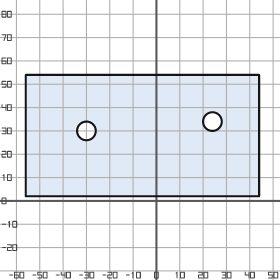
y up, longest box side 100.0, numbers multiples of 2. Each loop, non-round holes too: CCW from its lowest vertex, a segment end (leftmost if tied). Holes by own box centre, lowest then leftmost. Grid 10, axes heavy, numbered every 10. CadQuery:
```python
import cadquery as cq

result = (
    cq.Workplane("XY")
    .moveTo(-56.0, 2.0)
    .lineTo(44.0, 2.0)
    .lineTo(44.0, 54.0)
    .lineTo(-56.0, 54.0)
    .close()
    .moveTo(-30.0, 30.0)
    .circle(4.0)
    .moveTo(24.0, 34.0)
    .circle(4.0)
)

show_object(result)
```